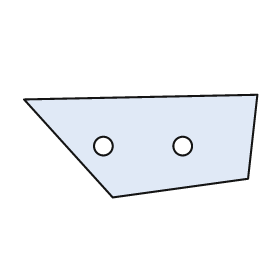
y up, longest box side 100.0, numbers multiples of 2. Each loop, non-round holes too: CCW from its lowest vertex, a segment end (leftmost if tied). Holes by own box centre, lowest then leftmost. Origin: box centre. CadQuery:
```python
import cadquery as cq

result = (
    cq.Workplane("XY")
    .moveTo(-12.0, -22.0)
    .lineTo(46.0, -14.0)
    .lineTo(50.0, 22.0)
    .lineTo(-50.0, 20.0)
    .close()
    .moveTo(-16.0, 0.0)
    .circle(4.0)
    .moveTo(18.0, 0.0)
    .circle(4.0)
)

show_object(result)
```